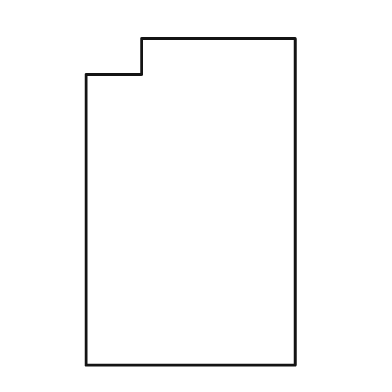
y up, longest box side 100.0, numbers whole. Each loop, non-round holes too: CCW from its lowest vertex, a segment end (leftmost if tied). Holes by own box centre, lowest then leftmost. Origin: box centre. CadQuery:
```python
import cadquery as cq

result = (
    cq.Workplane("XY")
    .moveTo(-32.0, -50.0)
    .lineTo(32.0, -50.0)
    .lineTo(32.0, 50.0)
    .lineTo(-15.0, 50.0)
    .lineTo(-15.0, 39.0)
    .lineTo(-32.0, 39.0)
    .close()
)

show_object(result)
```